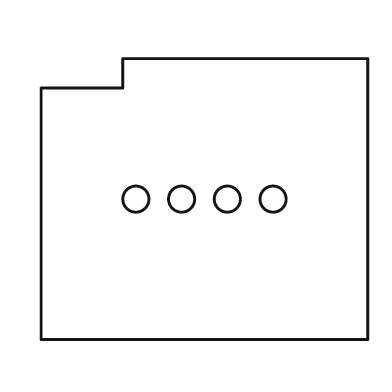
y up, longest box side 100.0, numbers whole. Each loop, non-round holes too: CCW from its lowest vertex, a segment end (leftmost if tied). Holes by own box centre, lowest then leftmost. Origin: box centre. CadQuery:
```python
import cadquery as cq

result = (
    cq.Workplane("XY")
    .moveTo(-50.0, -43.0)
    .lineTo(50.0, -43.0)
    .lineTo(50.0, 43.0)
    .lineTo(-25.0, 43.0)
    .lineTo(-25.0, 34.0)
    .lineTo(-50.0, 34.0)
    .close()
    .moveTo(-21.0, 0.0)
    .circle(4.0)
    .moveTo(-7.0, 0.0)
    .circle(4.0)
    .moveTo(7.0, 0.0)
    .circle(4.0)
    .moveTo(21.0, 0.0)
    .circle(4.0)
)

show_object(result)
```